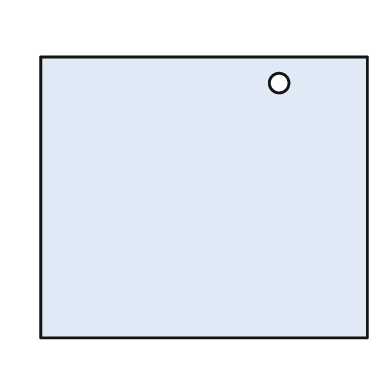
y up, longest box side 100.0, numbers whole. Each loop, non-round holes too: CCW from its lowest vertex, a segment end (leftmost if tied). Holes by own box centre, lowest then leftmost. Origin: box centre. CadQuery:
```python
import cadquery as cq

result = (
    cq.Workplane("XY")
    .moveTo(-50.0, -43.0)
    .lineTo(50.0, -43.0)
    .lineTo(50.0, 43.0)
    .lineTo(-50.0, 43.0)
    .close()
    .moveTo(23.0, 35.0)
    .circle(3.0)
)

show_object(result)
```